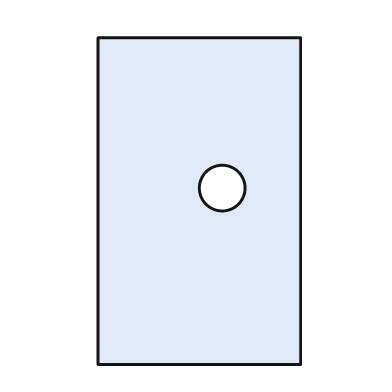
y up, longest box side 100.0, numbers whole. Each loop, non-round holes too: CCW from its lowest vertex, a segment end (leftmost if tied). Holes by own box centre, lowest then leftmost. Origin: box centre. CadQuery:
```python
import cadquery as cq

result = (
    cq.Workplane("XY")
    .moveTo(-31.0, -50.0)
    .lineTo(31.0, -50.0)
    .lineTo(31.0, 50.0)
    .lineTo(-31.0, 50.0)
    .close()
    .moveTo(7.0, 4.0)
    .circle(7.0)
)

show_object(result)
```